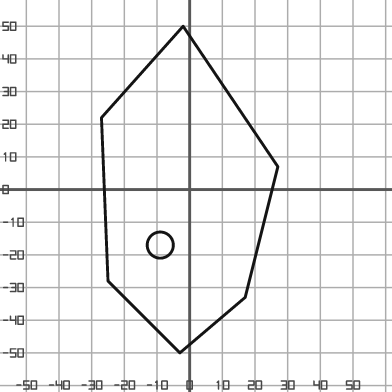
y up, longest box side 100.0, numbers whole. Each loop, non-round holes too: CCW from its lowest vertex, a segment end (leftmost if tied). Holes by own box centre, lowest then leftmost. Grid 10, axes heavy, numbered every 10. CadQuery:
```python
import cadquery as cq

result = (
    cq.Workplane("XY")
    .moveTo(-3.0, -50.0)
    .lineTo(17.0, -33.0)
    .lineTo(27.0, 7.0)
    .lineTo(-2.0, 50.0)
    .lineTo(-27.0, 22.0)
    .lineTo(-25.0, -28.0)
    .close()
    .moveTo(-9.0, -17.0)
    .circle(4.0)
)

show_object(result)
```